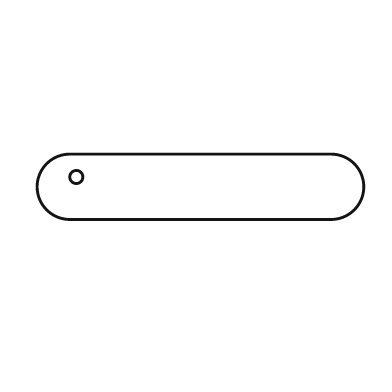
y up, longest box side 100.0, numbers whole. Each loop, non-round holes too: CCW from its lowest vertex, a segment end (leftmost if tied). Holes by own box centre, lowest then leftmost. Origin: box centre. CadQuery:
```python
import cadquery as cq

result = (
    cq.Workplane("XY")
    .moveTo(-40.0, -10.0)
    .lineTo(40.0, -10.0)
    .threePointArc((50.0, 0.0), (40.0, 10.0))
    .lineTo(-40.0, 10.0)
    .threePointArc((-50.0, 0.0), (-40.0, -10.0))
    .close()
    .moveTo(-38.0, 3.0)
    .circle(2.0)
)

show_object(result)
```